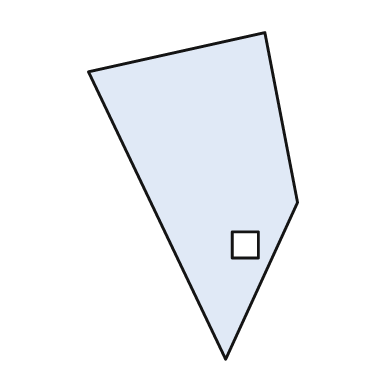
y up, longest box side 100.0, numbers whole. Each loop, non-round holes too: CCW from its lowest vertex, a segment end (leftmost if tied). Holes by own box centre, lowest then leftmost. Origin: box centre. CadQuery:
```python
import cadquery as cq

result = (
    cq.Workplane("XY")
    .moveTo(10.0, -50.0)
    .lineTo(32.0, -2.0)
    .lineTo(22.0, 50.0)
    .lineTo(-32.0, 38.0)
    .close()
    .moveTo(12.0, -19.0)
    .lineTo(20.0, -19.0)
    .lineTo(20.0, -11.0)
    .lineTo(12.0, -11.0)
    .close()
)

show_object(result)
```